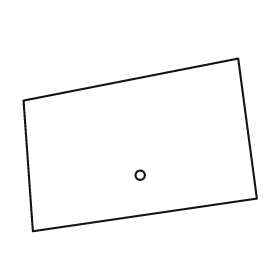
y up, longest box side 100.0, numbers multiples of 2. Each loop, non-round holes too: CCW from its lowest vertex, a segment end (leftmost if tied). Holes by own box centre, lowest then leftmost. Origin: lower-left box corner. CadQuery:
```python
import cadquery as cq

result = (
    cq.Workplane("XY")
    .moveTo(4.0, 0.0)
    .lineTo(100.0, 14.0)
    .lineTo(92.0, 74.0)
    .lineTo(0.0, 56.0)
    .close()
    .moveTo(50.0, 24.0)
    .circle(2.0)
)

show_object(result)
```